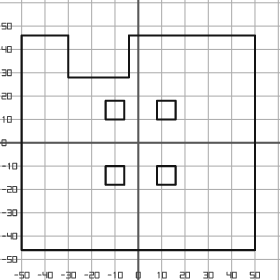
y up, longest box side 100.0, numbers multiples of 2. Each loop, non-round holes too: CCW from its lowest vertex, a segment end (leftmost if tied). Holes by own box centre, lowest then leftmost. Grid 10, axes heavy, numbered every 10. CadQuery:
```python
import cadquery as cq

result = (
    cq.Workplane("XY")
    .moveTo(-50.0, -46.0)
    .lineTo(50.0, -46.0)
    .lineTo(50.0, 46.0)
    .lineTo(-4.0, 46.0)
    .lineTo(-4.0, 28.0)
    .lineTo(-30.0, 28.0)
    .lineTo(-30.0, 46.0)
    .lineTo(-50.0, 46.0)
    .close()
    .moveTo(-14.0, -18.0)
    .lineTo(-6.0, -18.0)
    .lineTo(-6.0, -10.0)
    .lineTo(-14.0, -10.0)
    .close()
    .moveTo(8.0, -18.0)
    .lineTo(16.0, -18.0)
    .lineTo(16.0, -10.0)
    .lineTo(8.0, -10.0)
    .close()
    .moveTo(-14.0, 10.0)
    .lineTo(-6.0, 10.0)
    .lineTo(-6.0, 18.0)
    .lineTo(-14.0, 18.0)
    .close()
    .moveTo(8.0, 10.0)
    .lineTo(16.0, 10.0)
    .lineTo(16.0, 18.0)
    .lineTo(8.0, 18.0)
    .close()
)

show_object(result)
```